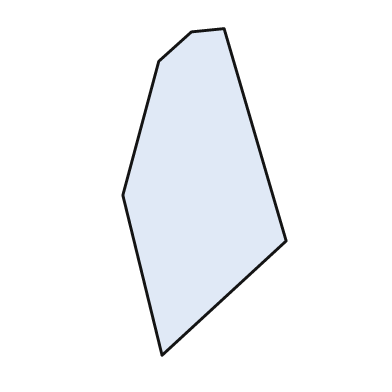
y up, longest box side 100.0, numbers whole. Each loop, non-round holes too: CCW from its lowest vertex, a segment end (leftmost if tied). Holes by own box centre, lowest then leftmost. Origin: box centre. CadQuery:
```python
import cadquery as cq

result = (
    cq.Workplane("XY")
    .moveTo(-13.0, -50.0)
    .lineTo(25.0, -15.0)
    .lineTo(6.0, 50.0)
    .lineTo(-4.0, 49.0)
    .lineTo(-14.0, 40.0)
    .lineTo(-25.0, -1.0)
    .close()
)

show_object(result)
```